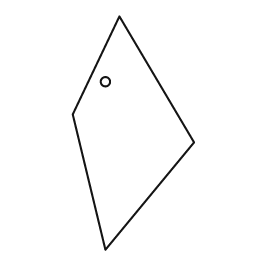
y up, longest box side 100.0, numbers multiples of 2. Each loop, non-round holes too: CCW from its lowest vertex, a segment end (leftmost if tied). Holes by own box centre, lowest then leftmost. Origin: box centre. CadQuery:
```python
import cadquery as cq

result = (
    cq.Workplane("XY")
    .moveTo(-12.0, -50.0)
    .lineTo(26.0, -4.0)
    .lineTo(-6.0, 50.0)
    .lineTo(-26.0, 8.0)
    .close()
    .moveTo(-12.0, 22.0)
    .circle(2.0)
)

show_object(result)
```